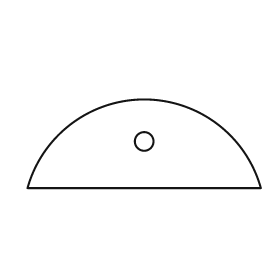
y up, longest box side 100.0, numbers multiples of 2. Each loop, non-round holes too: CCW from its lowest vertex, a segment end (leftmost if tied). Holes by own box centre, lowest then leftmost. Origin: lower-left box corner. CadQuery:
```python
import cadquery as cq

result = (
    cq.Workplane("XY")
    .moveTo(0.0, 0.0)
    .lineTo(100.0, 0.0)
    .threePointArc((50.0, 38.0), (0.0, 0.0))
    .close()
    .moveTo(50.0, 20.0)
    .circle(4.0)
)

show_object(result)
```